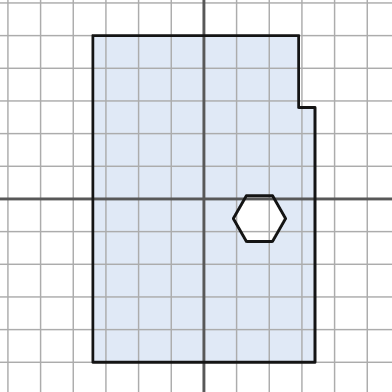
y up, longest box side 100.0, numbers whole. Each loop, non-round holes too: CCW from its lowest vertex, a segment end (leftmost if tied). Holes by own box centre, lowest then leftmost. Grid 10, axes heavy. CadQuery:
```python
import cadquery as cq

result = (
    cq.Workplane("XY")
    .moveTo(-34.0, -50.0)
    .lineTo(34.0, -50.0)
    .lineTo(34.0, 28.0)
    .lineTo(29.0, 28.0)
    .lineTo(29.0, 50.0)
    .lineTo(-34.0, 50.0)
    .close()
    .moveTo(13.0, -13.0)
    .lineTo(21.0, -13.0)
    .lineTo(25.0, -6.0)
    .lineTo(21.0, 1.0)
    .lineTo(13.0, 1.0)
    .lineTo(9.0, -6.0)
    .close()
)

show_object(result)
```